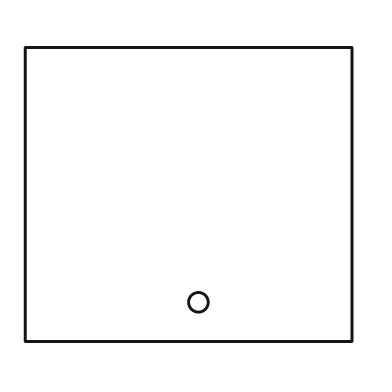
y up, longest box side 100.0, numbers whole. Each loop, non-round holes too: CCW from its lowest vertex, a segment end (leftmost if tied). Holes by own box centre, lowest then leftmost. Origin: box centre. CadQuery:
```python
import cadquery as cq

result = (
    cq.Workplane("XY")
    .moveTo(-50.0, -45.0)
    .lineTo(50.0, -45.0)
    .lineTo(50.0, 45.0)
    .lineTo(-50.0, 45.0)
    .close()
    .moveTo(3.0, -33.0)
    .circle(3.0)
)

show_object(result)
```